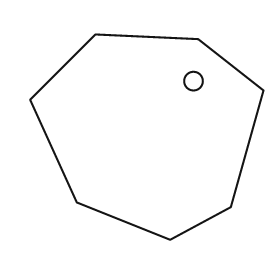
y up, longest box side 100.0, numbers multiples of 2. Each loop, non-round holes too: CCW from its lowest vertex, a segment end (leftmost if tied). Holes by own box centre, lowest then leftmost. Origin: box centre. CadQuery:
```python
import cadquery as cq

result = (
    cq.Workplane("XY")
    .moveTo(10.0, -44.0)
    .lineTo(36.0, -30.0)
    .lineTo(50.0, 20.0)
    .lineTo(22.0, 42.0)
    .lineTo(-22.0, 44.0)
    .lineTo(-50.0, 16.0)
    .lineTo(-30.0, -28.0)
    .close()
    .moveTo(20.0, 24.0)
    .circle(4.0)
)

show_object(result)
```